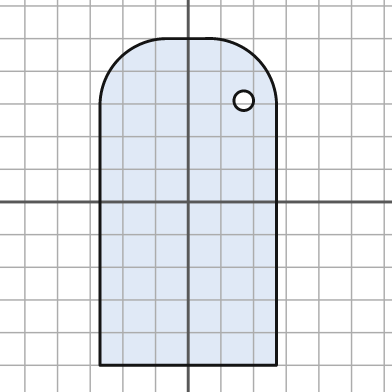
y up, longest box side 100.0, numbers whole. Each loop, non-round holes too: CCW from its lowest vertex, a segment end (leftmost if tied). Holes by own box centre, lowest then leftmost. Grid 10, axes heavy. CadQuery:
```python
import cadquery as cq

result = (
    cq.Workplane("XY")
    .moveTo(-27.0, -50.0)
    .lineTo(27.0, -50.0)
    .lineTo(27.0, 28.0)
    .threePointArc((21.0, 44.0), (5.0, 50.0))
    .lineTo(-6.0, 50.0)
    .threePointArc((-21.0, 44.0), (-27.0, 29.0))
    .close()
    .moveTo(17.0, 31.0)
    .circle(3.0)
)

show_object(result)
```